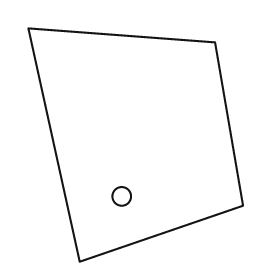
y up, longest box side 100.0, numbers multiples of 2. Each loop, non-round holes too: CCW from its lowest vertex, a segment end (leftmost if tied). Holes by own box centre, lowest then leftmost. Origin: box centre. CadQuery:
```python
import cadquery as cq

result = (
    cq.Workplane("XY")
    .moveTo(-24.0, -50.0)
    .lineTo(46.0, -26.0)
    .lineTo(34.0, 44.0)
    .lineTo(-46.0, 50.0)
    .close()
    .moveTo(-6.0, -22.0)
    .circle(4.0)
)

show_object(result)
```